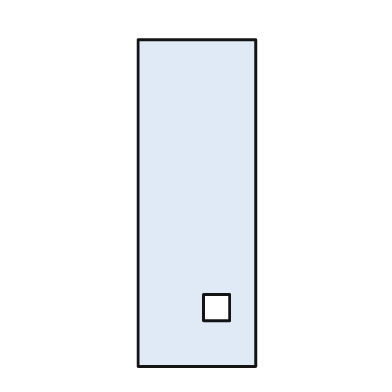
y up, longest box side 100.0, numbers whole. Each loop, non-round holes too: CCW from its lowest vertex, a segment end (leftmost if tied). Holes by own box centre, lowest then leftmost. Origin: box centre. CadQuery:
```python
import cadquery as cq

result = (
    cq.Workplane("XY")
    .moveTo(-18.0, -50.0)
    .lineTo(18.0, -50.0)
    .lineTo(18.0, 50.0)
    .lineTo(-18.0, 50.0)
    .close()
    .moveTo(2.0, -36.0)
    .lineTo(10.0, -36.0)
    .lineTo(10.0, -28.0)
    .lineTo(2.0, -28.0)
    .close()
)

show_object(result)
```